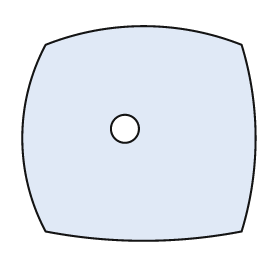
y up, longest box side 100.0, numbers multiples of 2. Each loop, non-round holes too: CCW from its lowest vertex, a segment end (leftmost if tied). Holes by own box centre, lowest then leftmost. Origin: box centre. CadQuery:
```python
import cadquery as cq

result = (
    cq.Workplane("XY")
    .moveTo(-40.0, -42.0)
    .threePointArc((2.0, -46.0), (44.0, -42.0))
    .threePointArc((50.0, -2.0), (44.0, 38.0))
    .threePointArc((2.0, 46.0), (-40.0, 38.0))
    .threePointArc((-50.0, -2.0), (-40.0, -42.0))
    .close()
    .moveTo(-6.0, 2.0)
    .circle(6.0)
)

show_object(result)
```